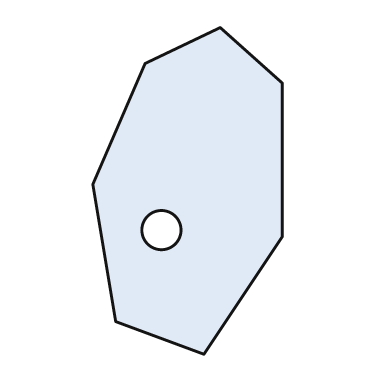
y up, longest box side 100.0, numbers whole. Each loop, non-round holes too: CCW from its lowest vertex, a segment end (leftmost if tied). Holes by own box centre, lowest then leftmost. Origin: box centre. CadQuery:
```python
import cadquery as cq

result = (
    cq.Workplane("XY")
    .moveTo(5.0, -50.0)
    .lineTo(29.0, -14.0)
    .lineTo(29.0, 33.0)
    .lineTo(10.0, 50.0)
    .lineTo(-13.0, 39.0)
    .lineTo(-29.0, 2.0)
    .lineTo(-22.0, -40.0)
    .close()
    .moveTo(-8.0, -12.0)
    .circle(6.0)
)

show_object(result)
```